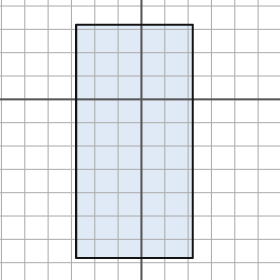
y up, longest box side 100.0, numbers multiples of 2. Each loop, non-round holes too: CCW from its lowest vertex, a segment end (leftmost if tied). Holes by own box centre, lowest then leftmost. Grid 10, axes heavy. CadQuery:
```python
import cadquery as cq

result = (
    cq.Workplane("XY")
    .moveTo(-28.0, -68.0)
    .lineTo(22.0, -68.0)
    .lineTo(22.0, 32.0)
    .lineTo(-28.0, 32.0)
    .close()
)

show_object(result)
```